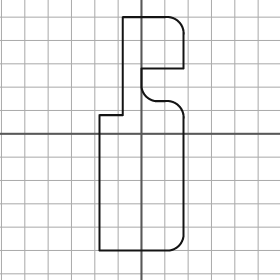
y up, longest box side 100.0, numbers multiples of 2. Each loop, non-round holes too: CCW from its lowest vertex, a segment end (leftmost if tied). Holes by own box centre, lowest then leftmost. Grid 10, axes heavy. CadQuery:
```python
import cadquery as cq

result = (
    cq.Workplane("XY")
    .moveTo(-18.0, -50.0)
    .lineTo(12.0, -50.0)
    .threePointArc((16.0, -48.0), (18.0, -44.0))
    .lineTo(18.0, 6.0)
    .threePointArc((16.0, 12.0), (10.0, 14.0))
    .lineTo(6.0, 14.0)
    .threePointArc((2.0, 16.0), (0.0, 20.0))
    .lineTo(0.0, 28.0)
    .lineTo(18.0, 28.0)
    .lineTo(18.0, 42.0)
    .threePointArc((16.0, 48.0), (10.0, 50.0))
    .lineTo(-8.0, 50.0)
    .lineTo(-8.0, 8.0)
    .lineTo(-18.0, 8.0)
    .close()
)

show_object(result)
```